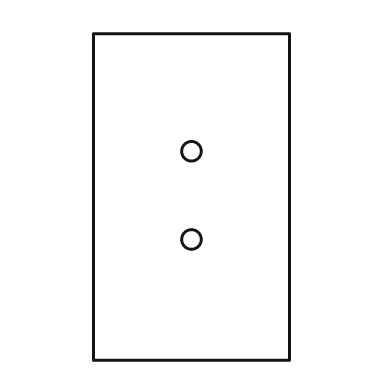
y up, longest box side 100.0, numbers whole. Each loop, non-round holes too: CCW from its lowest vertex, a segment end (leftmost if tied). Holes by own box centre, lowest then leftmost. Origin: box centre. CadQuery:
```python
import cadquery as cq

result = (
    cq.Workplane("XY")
    .moveTo(-30.0, -50.0)
    .lineTo(30.0, -50.0)
    .lineTo(30.0, 50.0)
    .lineTo(-30.0, 50.0)
    .close()
    .moveTo(0.0, -13.0)
    .circle(3.0)
    .moveTo(0.0, 14.0)
    .circle(3.0)
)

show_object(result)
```